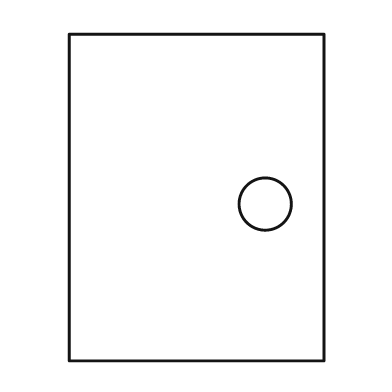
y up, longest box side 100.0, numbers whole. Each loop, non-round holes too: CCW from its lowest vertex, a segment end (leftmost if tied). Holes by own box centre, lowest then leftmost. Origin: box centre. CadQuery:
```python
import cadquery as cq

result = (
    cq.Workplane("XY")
    .moveTo(-39.0, -50.0)
    .lineTo(39.0, -50.0)
    .lineTo(39.0, 50.0)
    .lineTo(-39.0, 50.0)
    .close()
    .moveTo(21.0, -2.0)
    .circle(8.0)
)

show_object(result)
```